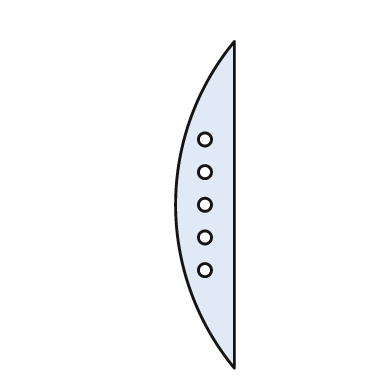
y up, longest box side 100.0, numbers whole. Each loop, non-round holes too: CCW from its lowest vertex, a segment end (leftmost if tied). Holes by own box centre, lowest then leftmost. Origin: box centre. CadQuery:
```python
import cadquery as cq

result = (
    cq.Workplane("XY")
    .moveTo(9.0, -50.0)
    .lineTo(9.0, 50.0)
    .threePointArc((-9.0, 0.0), (9.0, -50.0))
    .close()
    .moveTo(0.0, -20.0)
    .circle(2.0)
    .moveTo(0.0, -10.0)
    .circle(2.0)
    .moveTo(0.0, 0.0)
    .circle(2.0)
    .moveTo(0.0, 10.0)
    .circle(2.0)
    .moveTo(0.0, 20.0)
    .circle(2.0)
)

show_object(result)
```